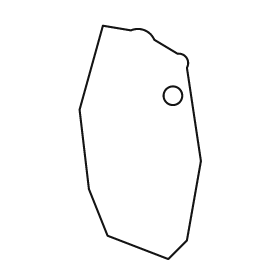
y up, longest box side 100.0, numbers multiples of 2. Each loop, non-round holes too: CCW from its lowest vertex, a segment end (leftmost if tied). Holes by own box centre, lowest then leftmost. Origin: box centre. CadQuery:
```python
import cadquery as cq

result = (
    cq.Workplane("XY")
    .moveTo(12.0, -50.0)
    .lineTo(20.0, -42.0)
    .lineTo(26.0, -8.0)
    .lineTo(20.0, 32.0)
    .threePointArc((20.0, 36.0), (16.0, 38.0))
    .lineTo(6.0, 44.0)
    .threePointArc((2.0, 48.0), (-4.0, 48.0))
    .lineTo(-16.0, 50.0)
    .lineTo(-26.0, 14.0)
    .lineTo(-22.0, -20.0)
    .lineTo(-14.0, -40.0)
    .close()
    .moveTo(14.0, 20.0)
    .circle(4.0)
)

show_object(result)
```